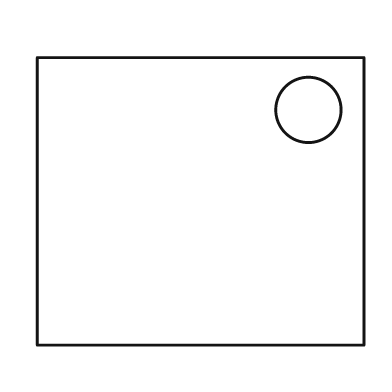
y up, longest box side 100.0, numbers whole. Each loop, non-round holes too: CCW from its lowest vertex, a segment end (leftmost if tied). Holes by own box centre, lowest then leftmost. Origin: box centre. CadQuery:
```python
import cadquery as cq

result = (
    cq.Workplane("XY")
    .moveTo(-50.0, -44.0)
    .lineTo(50.0, -44.0)
    .lineTo(50.0, 44.0)
    .lineTo(-50.0, 44.0)
    .close()
    .moveTo(33.0, 28.0)
    .circle(10.0)
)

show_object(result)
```